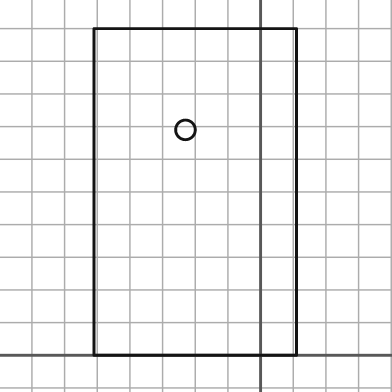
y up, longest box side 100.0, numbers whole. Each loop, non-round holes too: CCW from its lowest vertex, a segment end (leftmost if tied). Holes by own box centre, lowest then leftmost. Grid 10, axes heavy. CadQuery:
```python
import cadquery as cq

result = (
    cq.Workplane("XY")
    .moveTo(-51.0, 0.0)
    .lineTo(11.0, 0.0)
    .lineTo(11.0, 100.0)
    .lineTo(-51.0, 100.0)
    .close()
    .moveTo(-23.0, 69.0)
    .circle(3.0)
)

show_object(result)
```